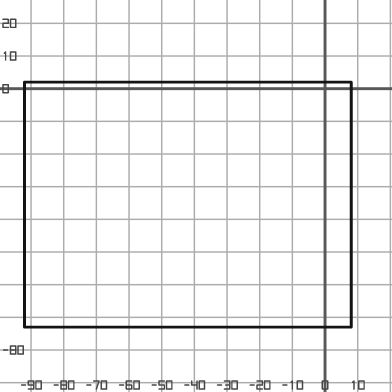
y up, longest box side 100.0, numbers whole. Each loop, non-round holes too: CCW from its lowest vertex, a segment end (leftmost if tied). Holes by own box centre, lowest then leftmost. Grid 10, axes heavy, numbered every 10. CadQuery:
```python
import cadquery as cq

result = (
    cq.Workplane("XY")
    .moveTo(-92.0, -73.0)
    .lineTo(8.0, -73.0)
    .lineTo(8.0, 2.0)
    .lineTo(-92.0, 2.0)
    .close()
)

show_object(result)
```